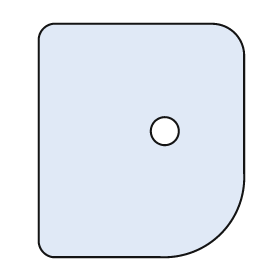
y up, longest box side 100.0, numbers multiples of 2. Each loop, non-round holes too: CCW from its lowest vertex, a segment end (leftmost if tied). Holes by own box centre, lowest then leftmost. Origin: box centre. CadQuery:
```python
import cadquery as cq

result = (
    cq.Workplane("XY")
    .moveTo(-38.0, -50.0)
    .lineTo(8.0, -50.0)
    .threePointArc((34.0, -40.0), (44.0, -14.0))
    .lineTo(44.0, 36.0)
    .threePointArc((40.0, 46.0), (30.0, 50.0))
    .lineTo(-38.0, 50.0)
    .threePointArc((-42.0, 48.0), (-44.0, 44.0))
    .lineTo(-44.0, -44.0)
    .threePointArc((-42.0, -48.0), (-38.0, -50.0))
    .close()
    .moveTo(10.0, 4.0)
    .circle(6.0)
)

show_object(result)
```